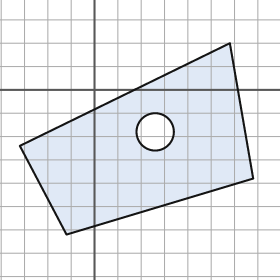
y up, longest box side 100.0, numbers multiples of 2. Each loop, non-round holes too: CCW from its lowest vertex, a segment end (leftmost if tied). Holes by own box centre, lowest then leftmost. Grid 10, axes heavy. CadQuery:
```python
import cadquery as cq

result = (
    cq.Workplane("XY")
    .moveTo(-12.0, -62.0)
    .lineTo(68.0, -38.0)
    .lineTo(58.0, 20.0)
    .lineTo(-32.0, -24.0)
    .close()
    .moveTo(26.0, -18.0)
    .circle(8.0)
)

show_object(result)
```